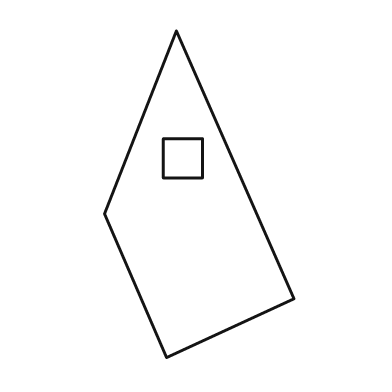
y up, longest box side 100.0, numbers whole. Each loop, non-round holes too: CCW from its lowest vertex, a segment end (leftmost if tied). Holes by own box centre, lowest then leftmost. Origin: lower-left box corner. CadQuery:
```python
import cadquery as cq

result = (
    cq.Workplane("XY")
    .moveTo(19.0, 0.0)
    .lineTo(58.0, 18.0)
    .lineTo(22.0, 100.0)
    .lineTo(0.0, 44.0)
    .close()
    .moveTo(18.0, 55.0)
    .lineTo(30.0, 55.0)
    .lineTo(30.0, 67.0)
    .lineTo(18.0, 67.0)
    .close()
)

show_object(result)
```